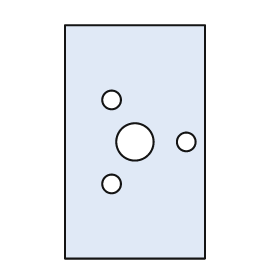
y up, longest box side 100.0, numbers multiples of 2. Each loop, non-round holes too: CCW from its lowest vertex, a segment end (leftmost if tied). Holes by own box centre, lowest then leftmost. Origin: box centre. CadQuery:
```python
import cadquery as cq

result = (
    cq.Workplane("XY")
    .moveTo(-30.0, -50.0)
    .lineTo(30.0, -50.0)
    .lineTo(30.0, 50.0)
    .lineTo(-30.0, 50.0)
    .close()
    .moveTo(-10.0, -18.0)
    .circle(4.0)
    .moveTo(0.0, 0.0)
    .circle(8.0)
    .moveTo(22.0, 0.0)
    .circle(4.0)
    .moveTo(-10.0, 18.0)
    .circle(4.0)
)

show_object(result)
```